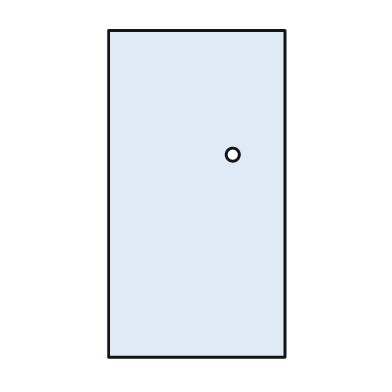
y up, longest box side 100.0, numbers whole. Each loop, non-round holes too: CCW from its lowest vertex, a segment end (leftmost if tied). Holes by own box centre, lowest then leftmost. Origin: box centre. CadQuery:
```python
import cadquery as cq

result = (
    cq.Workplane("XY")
    .moveTo(-27.0, -50.0)
    .lineTo(27.0, -50.0)
    .lineTo(27.0, 50.0)
    .lineTo(-27.0, 50.0)
    .close()
    .moveTo(11.0, 12.0)
    .circle(2.0)
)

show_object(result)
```